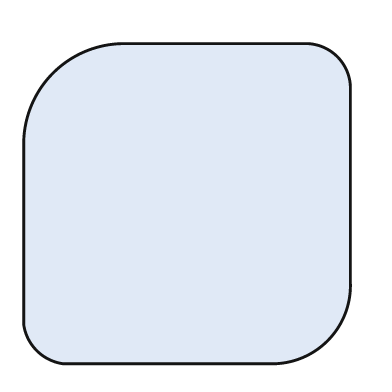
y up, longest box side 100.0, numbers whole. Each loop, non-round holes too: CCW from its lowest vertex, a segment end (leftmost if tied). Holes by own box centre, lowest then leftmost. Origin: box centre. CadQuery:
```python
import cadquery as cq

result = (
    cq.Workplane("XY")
    .moveTo(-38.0, -49.0)
    .lineTo(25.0, -49.0)
    .threePointArc((43.0, -42.0), (50.0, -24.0))
    .lineTo(50.0, 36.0)
    .threePointArc((46.0, 45.0), (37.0, 49.0))
    .lineTo(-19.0, 49.0)
    .threePointArc((-41.0, 40.0), (-50.0, 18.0))
    .lineTo(-50.0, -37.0)
    .threePointArc((-46.0, -45.0), (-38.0, -49.0))
    .close()
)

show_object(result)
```